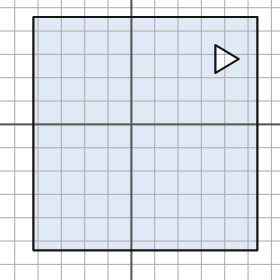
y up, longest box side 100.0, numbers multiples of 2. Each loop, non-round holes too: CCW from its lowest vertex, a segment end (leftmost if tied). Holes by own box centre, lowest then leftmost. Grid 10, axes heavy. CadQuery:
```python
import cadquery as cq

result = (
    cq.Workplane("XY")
    .moveTo(-42.0, -54.0)
    .lineTo(54.0, -54.0)
    .lineTo(54.0, 46.0)
    .lineTo(-42.0, 46.0)
    .close()
    .moveTo(36.0, 22.0)
    .lineTo(46.0, 28.0)
    .lineTo(36.0, 34.0)
    .close()
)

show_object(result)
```